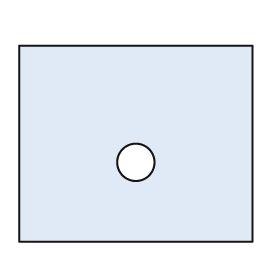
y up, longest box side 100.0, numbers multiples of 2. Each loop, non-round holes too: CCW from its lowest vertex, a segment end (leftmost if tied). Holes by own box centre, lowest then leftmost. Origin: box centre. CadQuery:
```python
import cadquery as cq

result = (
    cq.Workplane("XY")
    .moveTo(-50.0, -42.0)
    .lineTo(50.0, -42.0)
    .lineTo(50.0, 42.0)
    .lineTo(-50.0, 42.0)
    .close()
    .moveTo(0.0, -8.0)
    .circle(8.0)
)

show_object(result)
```